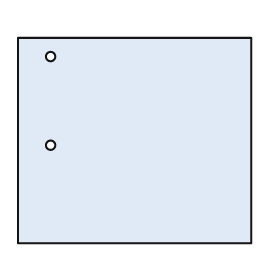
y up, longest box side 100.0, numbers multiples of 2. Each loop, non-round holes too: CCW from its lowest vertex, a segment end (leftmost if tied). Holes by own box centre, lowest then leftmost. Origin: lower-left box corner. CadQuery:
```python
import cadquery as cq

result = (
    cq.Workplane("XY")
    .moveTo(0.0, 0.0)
    .lineTo(100.0, 0.0)
    .lineTo(100.0, 88.0)
    .lineTo(0.0, 88.0)
    .close()
    .moveTo(14.0, 42.0)
    .circle(2.0)
    .moveTo(14.0, 80.0)
    .circle(2.0)
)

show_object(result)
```